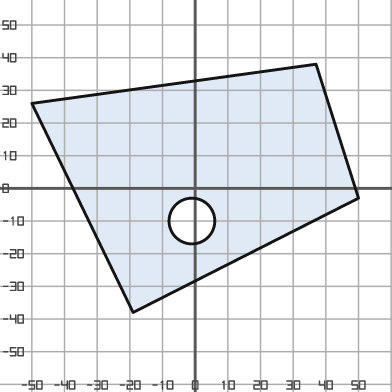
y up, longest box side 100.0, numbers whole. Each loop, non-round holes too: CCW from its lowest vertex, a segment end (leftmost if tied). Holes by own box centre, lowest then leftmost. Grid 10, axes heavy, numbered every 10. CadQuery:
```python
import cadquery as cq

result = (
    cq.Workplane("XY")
    .moveTo(-19.0, -38.0)
    .lineTo(50.0, -3.0)
    .lineTo(37.0, 38.0)
    .lineTo(-50.0, 26.0)
    .close()
    .moveTo(-1.0, -10.0)
    .circle(7.0)
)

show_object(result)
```